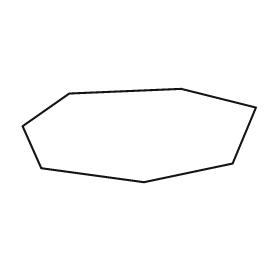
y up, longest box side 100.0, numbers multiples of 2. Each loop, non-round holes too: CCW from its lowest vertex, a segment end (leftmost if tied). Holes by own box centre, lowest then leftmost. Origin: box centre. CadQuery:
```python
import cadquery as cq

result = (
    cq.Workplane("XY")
    .moveTo(2.0, -20.0)
    .lineTo(40.0, -12.0)
    .lineTo(50.0, 12.0)
    .lineTo(18.0, 20.0)
    .lineTo(-30.0, 18.0)
    .lineTo(-50.0, 4.0)
    .lineTo(-42.0, -14.0)
    .close()
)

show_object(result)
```